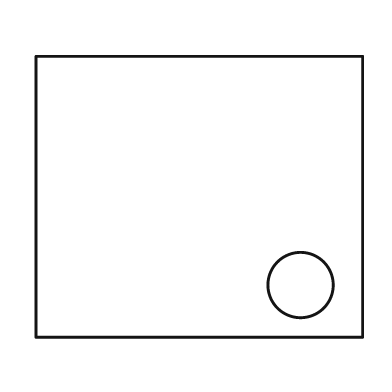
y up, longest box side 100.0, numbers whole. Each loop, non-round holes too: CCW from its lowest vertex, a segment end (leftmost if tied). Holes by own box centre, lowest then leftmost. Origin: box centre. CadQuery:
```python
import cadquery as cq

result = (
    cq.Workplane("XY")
    .moveTo(-50.0, -43.0)
    .lineTo(50.0, -43.0)
    .lineTo(50.0, 43.0)
    .lineTo(-50.0, 43.0)
    .close()
    .moveTo(31.0, -27.0)
    .circle(10.0)
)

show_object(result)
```